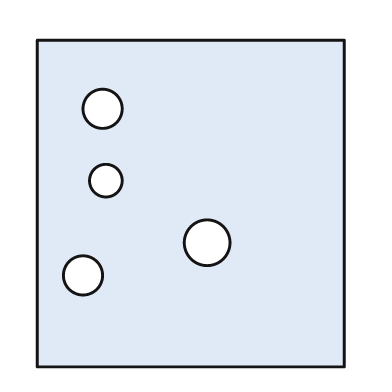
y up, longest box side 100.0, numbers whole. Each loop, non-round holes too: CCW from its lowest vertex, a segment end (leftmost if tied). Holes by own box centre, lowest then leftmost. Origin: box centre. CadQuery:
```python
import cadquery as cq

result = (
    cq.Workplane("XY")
    .moveTo(-47.0, -50.0)
    .lineTo(47.0, -50.0)
    .lineTo(47.0, 50.0)
    .lineTo(-47.0, 50.0)
    .close()
    .moveTo(-33.0, -22.0)
    .circle(6.0)
    .moveTo(5.0, -12.0)
    .circle(7.0)
    .moveTo(-26.0, 7.0)
    .circle(5.0)
    .moveTo(-27.0, 29.0)
    .circle(6.0)
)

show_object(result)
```